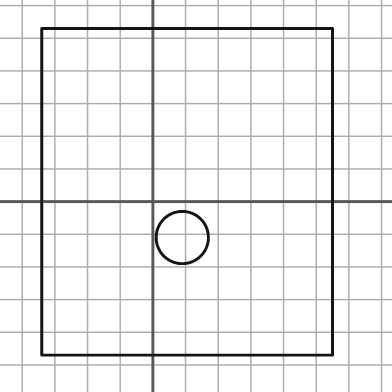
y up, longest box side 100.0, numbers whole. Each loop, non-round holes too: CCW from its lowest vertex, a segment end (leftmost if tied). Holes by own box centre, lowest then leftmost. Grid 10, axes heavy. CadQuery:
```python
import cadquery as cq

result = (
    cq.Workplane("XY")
    .moveTo(-34.0, -47.0)
    .lineTo(55.0, -47.0)
    .lineTo(55.0, 53.0)
    .lineTo(-34.0, 53.0)
    .close()
    .moveTo(9.0, -11.0)
    .circle(8.0)
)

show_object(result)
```